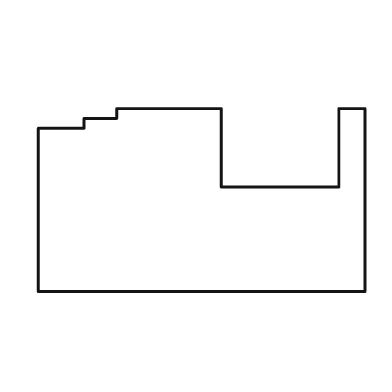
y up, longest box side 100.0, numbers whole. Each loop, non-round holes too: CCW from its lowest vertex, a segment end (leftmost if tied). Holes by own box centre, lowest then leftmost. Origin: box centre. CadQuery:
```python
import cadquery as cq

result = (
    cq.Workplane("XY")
    .moveTo(-50.0, -28.0)
    .lineTo(50.0, -28.0)
    .lineTo(50.0, 28.0)
    .lineTo(42.0, 28.0)
    .lineTo(42.0, 4.0)
    .lineTo(6.0, 4.0)
    .lineTo(6.0, 28.0)
    .lineTo(-26.0, 28.0)
    .lineTo(-26.0, 25.0)
    .lineTo(-36.0, 25.0)
    .lineTo(-36.0, 22.0)
    .lineTo(-50.0, 22.0)
    .close()
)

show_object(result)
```